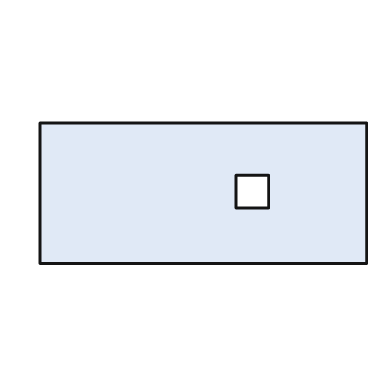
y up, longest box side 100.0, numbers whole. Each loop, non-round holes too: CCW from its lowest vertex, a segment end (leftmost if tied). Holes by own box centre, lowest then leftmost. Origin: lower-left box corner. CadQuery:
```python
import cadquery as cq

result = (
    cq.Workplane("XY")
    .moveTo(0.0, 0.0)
    .lineTo(100.0, 0.0)
    .lineTo(100.0, 43.0)
    .lineTo(0.0, 43.0)
    .close()
    .moveTo(60.0, 17.0)
    .lineTo(70.0, 17.0)
    .lineTo(70.0, 27.0)
    .lineTo(60.0, 27.0)
    .close()
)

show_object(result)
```